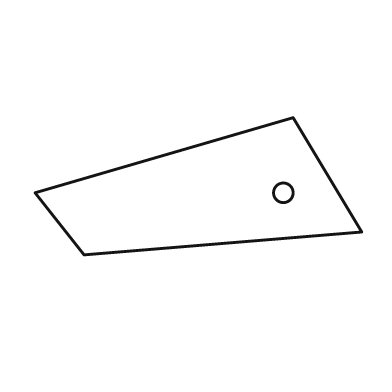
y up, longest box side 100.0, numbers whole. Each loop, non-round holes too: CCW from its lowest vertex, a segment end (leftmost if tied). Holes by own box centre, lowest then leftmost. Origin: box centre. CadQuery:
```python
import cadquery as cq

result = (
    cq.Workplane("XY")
    .moveTo(-35.0, -21.0)
    .lineTo(50.0, -14.0)
    .lineTo(29.0, 21.0)
    .lineTo(-50.0, -2.0)
    .close()
    .moveTo(26.0, -2.0)
    .circle(3.0)
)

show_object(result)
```